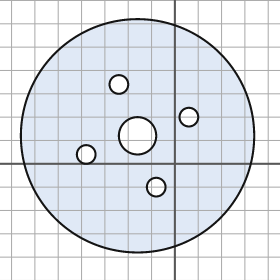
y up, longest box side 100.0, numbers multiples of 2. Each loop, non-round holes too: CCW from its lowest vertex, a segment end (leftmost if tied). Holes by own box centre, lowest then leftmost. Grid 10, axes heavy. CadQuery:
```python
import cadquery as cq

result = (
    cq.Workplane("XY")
    .moveTo(-16.0, 12.0)
    .circle(50.0)
    .moveTo(-8.0, -10.0)
    .circle(4.0)
    .moveTo(-38.0, 4.0)
    .circle(4.0)
    .moveTo(-16.0, 12.0)
    .circle(8.0)
    .moveTo(6.0, 20.0)
    .circle(4.0)
    .moveTo(-24.0, 34.0)
    .circle(4.0)
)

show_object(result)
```